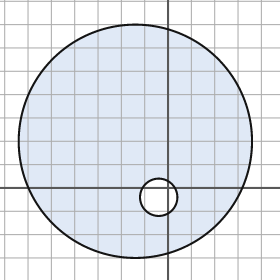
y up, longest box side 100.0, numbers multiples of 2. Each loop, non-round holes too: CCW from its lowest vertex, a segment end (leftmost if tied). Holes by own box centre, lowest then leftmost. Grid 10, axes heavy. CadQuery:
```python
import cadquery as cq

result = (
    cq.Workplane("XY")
    .moveTo(-14.0, 20.0)
    .circle(50.0)
    .moveTo(-4.0, -4.0)
    .circle(8.0)
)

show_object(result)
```